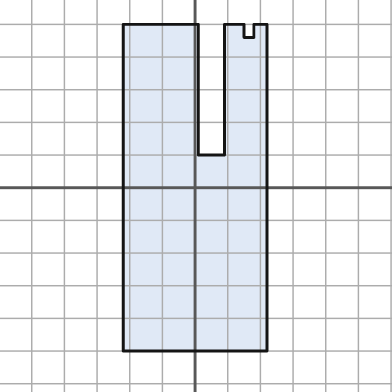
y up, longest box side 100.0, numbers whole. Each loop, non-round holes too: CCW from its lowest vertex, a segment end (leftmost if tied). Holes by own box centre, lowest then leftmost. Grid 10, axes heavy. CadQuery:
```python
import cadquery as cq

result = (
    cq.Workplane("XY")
    .moveTo(-22.0, -50.0)
    .lineTo(22.0, -50.0)
    .lineTo(22.0, 50.0)
    .lineTo(18.0, 50.0)
    .lineTo(18.0, 46.0)
    .lineTo(15.0, 46.0)
    .lineTo(15.0, 50.0)
    .lineTo(9.0, 50.0)
    .lineTo(9.0, 10.0)
    .lineTo(1.0, 10.0)
    .lineTo(1.0, 50.0)
    .lineTo(-22.0, 50.0)
    .close()
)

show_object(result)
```